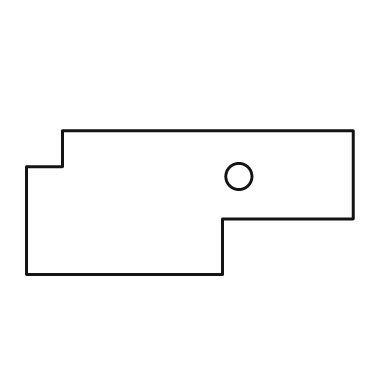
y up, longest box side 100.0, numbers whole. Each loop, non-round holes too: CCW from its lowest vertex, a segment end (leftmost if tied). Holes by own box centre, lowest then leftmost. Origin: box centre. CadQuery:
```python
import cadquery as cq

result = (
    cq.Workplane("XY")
    .moveTo(-50.0, -22.0)
    .lineTo(10.0, -22.0)
    .lineTo(10.0, -5.0)
    .lineTo(50.0, -5.0)
    .lineTo(50.0, 22.0)
    .lineTo(-39.0, 22.0)
    .lineTo(-39.0, 11.0)
    .lineTo(-50.0, 11.0)
    .close()
    .moveTo(15.0, 8.0)
    .circle(4.0)
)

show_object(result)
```